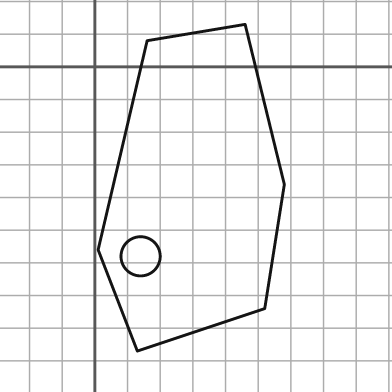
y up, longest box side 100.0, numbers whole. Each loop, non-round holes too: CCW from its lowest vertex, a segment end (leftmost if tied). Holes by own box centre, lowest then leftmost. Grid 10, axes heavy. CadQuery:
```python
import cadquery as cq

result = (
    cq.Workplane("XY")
    .moveTo(13.0, -87.0)
    .lineTo(52.0, -74.0)
    .lineTo(58.0, -36.0)
    .lineTo(46.0, 13.0)
    .lineTo(16.0, 8.0)
    .lineTo(1.0, -56.0)
    .close()
    .moveTo(14.0, -58.0)
    .circle(6.0)
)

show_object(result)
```